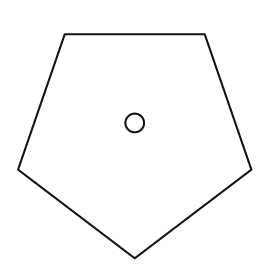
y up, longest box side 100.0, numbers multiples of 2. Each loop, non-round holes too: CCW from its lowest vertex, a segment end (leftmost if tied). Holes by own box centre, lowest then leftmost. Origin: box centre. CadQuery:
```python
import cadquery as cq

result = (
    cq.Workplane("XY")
    .moveTo(0.0, -48.0)
    .lineTo(50.0, -10.0)
    .lineTo(30.0, 48.0)
    .lineTo(-30.0, 48.0)
    .lineTo(-50.0, -10.0)
    .close()
    .moveTo(0.0, 10.0)
    .circle(4.0)
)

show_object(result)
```